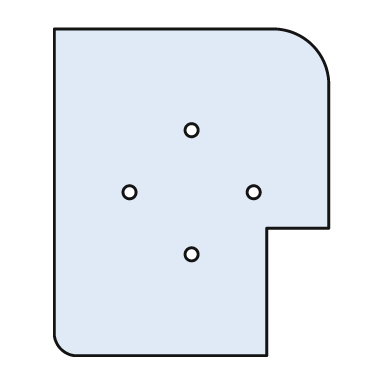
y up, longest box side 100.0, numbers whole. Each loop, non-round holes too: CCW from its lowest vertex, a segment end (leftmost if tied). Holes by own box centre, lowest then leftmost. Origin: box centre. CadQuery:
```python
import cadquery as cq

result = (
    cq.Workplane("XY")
    .moveTo(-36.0, -50.0)
    .lineTo(23.0, -50.0)
    .lineTo(23.0, -11.0)
    .lineTo(42.0, -11.0)
    .lineTo(42.0, 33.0)
    .threePointArc((37.0, 45.0), (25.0, 50.0))
    .lineTo(-42.0, 50.0)
    .lineTo(-42.0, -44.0)
    .threePointArc((-40.0, -48.0), (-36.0, -50.0))
    .close()
    .moveTo(0.0, -19.0)
    .circle(2.0)
    .moveTo(-19.0, 0.0)
    .circle(2.0)
    .moveTo(19.0, 0.0)
    .circle(2.0)
    .moveTo(0.0, 19.0)
    .circle(2.0)
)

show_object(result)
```